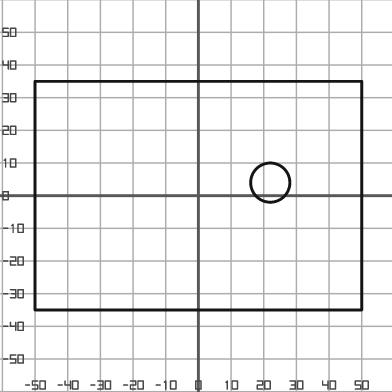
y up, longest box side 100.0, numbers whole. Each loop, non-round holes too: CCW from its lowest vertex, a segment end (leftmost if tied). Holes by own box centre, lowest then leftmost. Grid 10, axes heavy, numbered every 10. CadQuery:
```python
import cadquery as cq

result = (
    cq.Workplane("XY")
    .moveTo(-50.0, -35.0)
    .lineTo(50.0, -35.0)
    .lineTo(50.0, 35.0)
    .lineTo(-50.0, 35.0)
    .close()
    .moveTo(22.0, 4.0)
    .circle(6.0)
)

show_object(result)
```